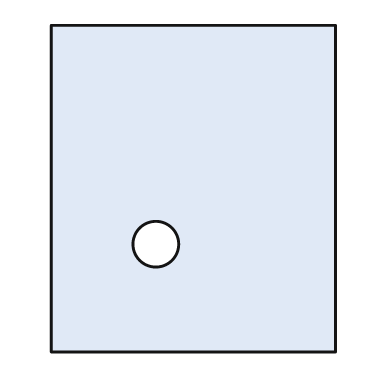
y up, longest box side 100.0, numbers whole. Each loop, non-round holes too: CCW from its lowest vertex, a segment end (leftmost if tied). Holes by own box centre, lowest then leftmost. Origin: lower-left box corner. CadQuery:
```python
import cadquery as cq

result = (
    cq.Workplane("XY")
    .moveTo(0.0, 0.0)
    .lineTo(87.0, 0.0)
    .lineTo(87.0, 100.0)
    .lineTo(0.0, 100.0)
    .close()
    .moveTo(32.0, 33.0)
    .circle(7.0)
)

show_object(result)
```